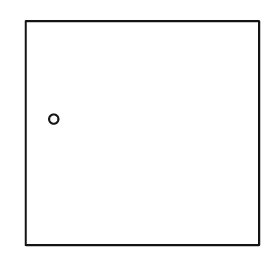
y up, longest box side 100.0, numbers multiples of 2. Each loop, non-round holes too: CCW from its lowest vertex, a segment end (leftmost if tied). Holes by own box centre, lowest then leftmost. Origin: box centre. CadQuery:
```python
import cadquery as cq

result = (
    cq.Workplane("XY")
    .moveTo(-50.0, -48.0)
    .lineTo(50.0, -48.0)
    .lineTo(50.0, 48.0)
    .lineTo(-50.0, 48.0)
    .close()
    .moveTo(-38.0, 6.0)
    .circle(2.0)
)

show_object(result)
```